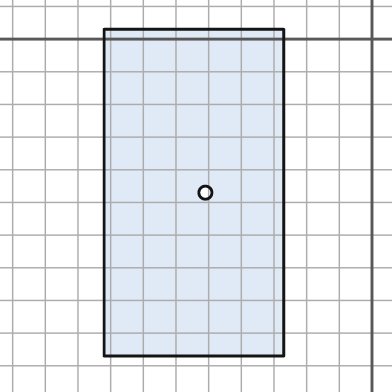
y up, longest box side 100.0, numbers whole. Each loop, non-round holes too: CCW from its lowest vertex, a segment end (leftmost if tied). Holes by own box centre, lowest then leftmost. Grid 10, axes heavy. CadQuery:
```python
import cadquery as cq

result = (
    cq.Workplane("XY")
    .moveTo(-82.0, -97.0)
    .lineTo(-27.0, -97.0)
    .lineTo(-27.0, 3.0)
    .lineTo(-82.0, 3.0)
    .close()
    .moveTo(-51.0, -47.0)
    .circle(2.0)
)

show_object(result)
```